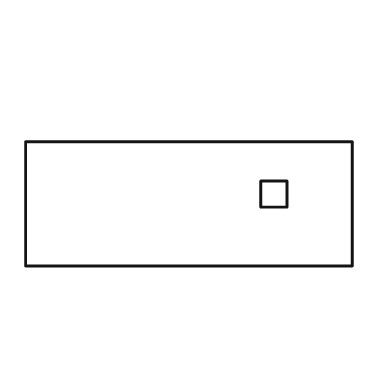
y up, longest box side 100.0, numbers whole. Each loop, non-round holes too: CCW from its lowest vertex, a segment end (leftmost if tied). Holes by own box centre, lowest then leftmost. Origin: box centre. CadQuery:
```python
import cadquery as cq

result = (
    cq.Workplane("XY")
    .moveTo(-50.0, -19.0)
    .lineTo(50.0, -19.0)
    .lineTo(50.0, 19.0)
    .lineTo(-50.0, 19.0)
    .close()
    .moveTo(22.0, -1.0)
    .lineTo(30.0, -1.0)
    .lineTo(30.0, 7.0)
    .lineTo(22.0, 7.0)
    .close()
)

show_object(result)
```